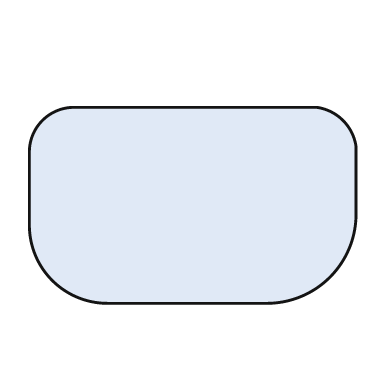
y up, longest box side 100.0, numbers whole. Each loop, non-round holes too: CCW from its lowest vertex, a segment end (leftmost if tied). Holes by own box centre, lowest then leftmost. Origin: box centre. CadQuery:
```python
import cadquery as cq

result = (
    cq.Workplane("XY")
    .moveTo(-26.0, -30.0)
    .lineTo(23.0, -30.0)
    .threePointArc((42.0, -22.0), (50.0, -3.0))
    .lineTo(50.0, 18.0)
    .threePointArc((46.0, 26.0), (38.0, 30.0))
    .lineTo(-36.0, 30.0)
    .threePointArc((-46.0, 26.0), (-50.0, 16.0))
    .lineTo(-50.0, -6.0)
    .threePointArc((-43.0, -23.0), (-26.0, -30.0))
    .close()
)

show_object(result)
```